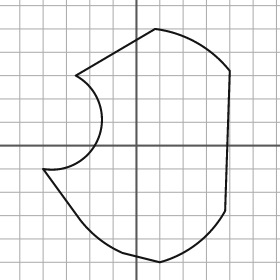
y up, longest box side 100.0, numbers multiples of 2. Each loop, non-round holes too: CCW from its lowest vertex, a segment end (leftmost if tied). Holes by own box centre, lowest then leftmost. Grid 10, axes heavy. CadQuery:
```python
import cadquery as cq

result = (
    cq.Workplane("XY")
    .moveTo(10.0, -50.0)
    .threePointArc((26.0, -42.0), (38.0, -28.0))
    .lineTo(40.0, 32.0)
    .threePointArc((26.0, 44.0), (8.0, 50.0))
    .lineTo(-26.0, 30.0)
    .threePointArc((-16.0, 4.0), (-40.0, -10.0))
    .lineTo(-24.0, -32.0)
    .threePointArc((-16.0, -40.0), (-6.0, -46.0))
    .close()
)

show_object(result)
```